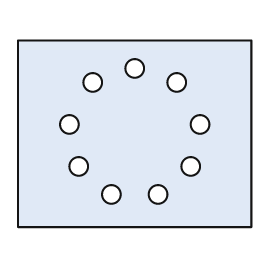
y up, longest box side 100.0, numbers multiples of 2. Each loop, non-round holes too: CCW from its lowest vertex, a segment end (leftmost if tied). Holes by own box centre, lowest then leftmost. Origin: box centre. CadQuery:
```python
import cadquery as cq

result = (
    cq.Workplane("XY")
    .moveTo(-50.0, -40.0)
    .lineTo(50.0, -40.0)
    .lineTo(50.0, 40.0)
    .lineTo(-50.0, 40.0)
    .close()
    .moveTo(-10.0, -26.0)
    .circle(4.0)
    .moveTo(10.0, -26.0)
    .circle(4.0)
    .moveTo(-24.0, -14.0)
    .circle(4.0)
    .moveTo(24.0, -14.0)
    .circle(4.0)
    .moveTo(-28.0, 4.0)
    .circle(4.0)
    .moveTo(28.0, 4.0)
    .circle(4.0)
    .moveTo(-18.0, 22.0)
    .circle(4.0)
    .moveTo(18.0, 22.0)
    .circle(4.0)
    .moveTo(0.0, 28.0)
    .circle(4.0)
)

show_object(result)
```